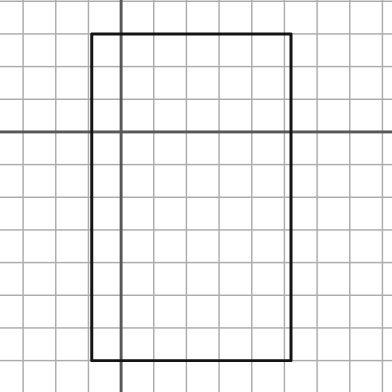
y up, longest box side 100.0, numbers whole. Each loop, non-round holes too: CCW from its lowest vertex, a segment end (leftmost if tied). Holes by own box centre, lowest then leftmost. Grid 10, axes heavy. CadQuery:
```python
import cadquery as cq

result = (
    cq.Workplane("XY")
    .moveTo(-9.0, -70.0)
    .lineTo(52.0, -70.0)
    .lineTo(52.0, 30.0)
    .lineTo(-9.0, 30.0)
    .close()
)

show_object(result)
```